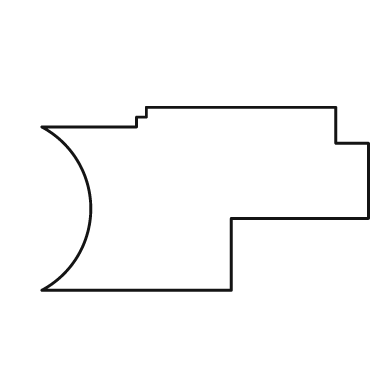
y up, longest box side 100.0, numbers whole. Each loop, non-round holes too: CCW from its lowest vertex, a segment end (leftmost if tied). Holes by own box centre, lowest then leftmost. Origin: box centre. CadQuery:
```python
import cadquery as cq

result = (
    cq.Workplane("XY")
    .moveTo(-50.0, -28.0)
    .lineTo(8.0, -28.0)
    .lineTo(8.0, -6.0)
    .lineTo(50.0, -6.0)
    .lineTo(50.0, 17.0)
    .lineTo(40.0, 17.0)
    .lineTo(40.0, 28.0)
    .lineTo(-18.0, 28.0)
    .lineTo(-18.0, 25.0)
    .lineTo(-21.0, 25.0)
    .lineTo(-21.0, 22.0)
    .lineTo(-50.0, 22.0)
    .threePointArc((-35.0, -3.0), (-50.0, -28.0))
    .close()
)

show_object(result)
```